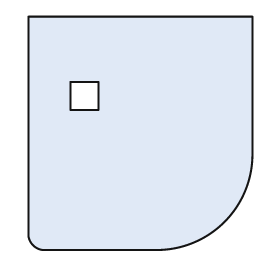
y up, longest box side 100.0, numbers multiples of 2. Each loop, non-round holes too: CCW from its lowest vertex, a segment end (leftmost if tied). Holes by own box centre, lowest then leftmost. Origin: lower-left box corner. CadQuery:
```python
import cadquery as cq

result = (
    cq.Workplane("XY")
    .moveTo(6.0, 0.0)
    .lineTo(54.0, 0.0)
    .threePointArc((84.0, 12.0), (96.0, 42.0))
    .lineTo(96.0, 100.0)
    .lineTo(0.0, 100.0)
    .lineTo(0.0, 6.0)
    .threePointArc((2.0, 2.0), (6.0, 0.0))
    .close()
    .moveTo(18.0, 60.0)
    .lineTo(30.0, 60.0)
    .lineTo(30.0, 72.0)
    .lineTo(18.0, 72.0)
    .close()
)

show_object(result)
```